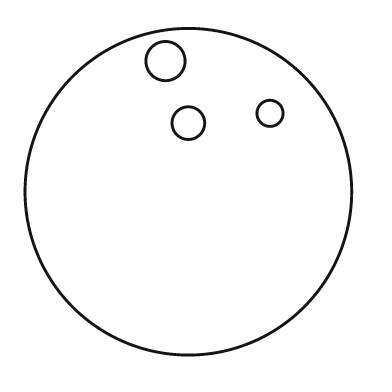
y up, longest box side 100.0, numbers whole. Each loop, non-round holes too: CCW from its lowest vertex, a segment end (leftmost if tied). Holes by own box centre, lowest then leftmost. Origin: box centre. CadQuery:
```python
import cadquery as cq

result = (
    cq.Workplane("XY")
    .moveTo(0.0, 0.0)
    .circle(50.0)
    .moveTo(0.0, 21.0)
    .circle(5.0)
    .moveTo(25.0, 24.0)
    .circle(4.0)
    .moveTo(-7.0, 40.0)
    .circle(6.0)
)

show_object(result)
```